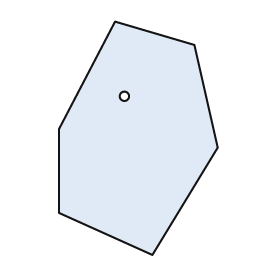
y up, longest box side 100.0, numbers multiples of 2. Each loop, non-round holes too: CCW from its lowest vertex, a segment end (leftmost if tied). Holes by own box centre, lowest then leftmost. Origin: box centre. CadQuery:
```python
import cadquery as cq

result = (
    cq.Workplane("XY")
    .moveTo(6.0, -50.0)
    .lineTo(34.0, -4.0)
    .lineTo(24.0, 40.0)
    .lineTo(-10.0, 50.0)
    .lineTo(-34.0, 4.0)
    .lineTo(-34.0, -32.0)
    .close()
    .moveTo(-6.0, 18.0)
    .circle(2.0)
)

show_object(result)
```